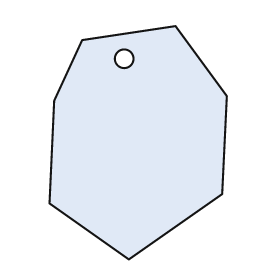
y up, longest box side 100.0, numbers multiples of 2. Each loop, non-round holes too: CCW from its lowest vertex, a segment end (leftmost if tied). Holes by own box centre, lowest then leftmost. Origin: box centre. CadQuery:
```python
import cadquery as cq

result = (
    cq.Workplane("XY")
    .moveTo(-4.0, -50.0)
    .lineTo(36.0, -22.0)
    .lineTo(38.0, 20.0)
    .lineTo(16.0, 50.0)
    .lineTo(-24.0, 44.0)
    .lineTo(-36.0, 18.0)
    .lineTo(-38.0, -26.0)
    .close()
    .moveTo(-6.0, 36.0)
    .circle(4.0)
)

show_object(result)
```